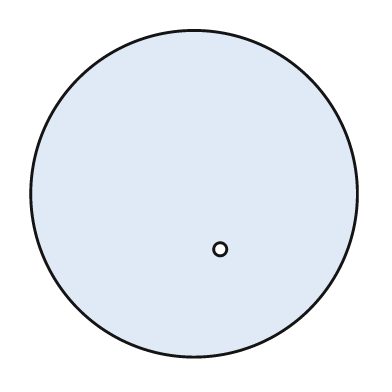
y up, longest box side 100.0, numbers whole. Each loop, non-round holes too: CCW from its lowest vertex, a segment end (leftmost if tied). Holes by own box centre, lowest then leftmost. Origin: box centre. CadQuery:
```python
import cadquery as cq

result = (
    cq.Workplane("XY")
    .moveTo(0.0, 0.0)
    .circle(50.0)
    .moveTo(8.0, -17.0)
    .circle(2.0)
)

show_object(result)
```